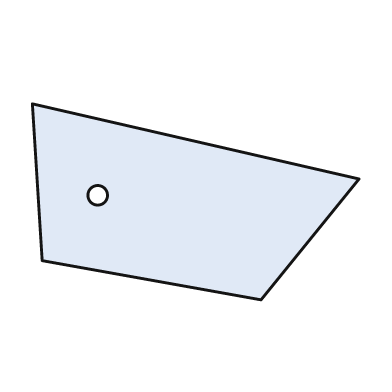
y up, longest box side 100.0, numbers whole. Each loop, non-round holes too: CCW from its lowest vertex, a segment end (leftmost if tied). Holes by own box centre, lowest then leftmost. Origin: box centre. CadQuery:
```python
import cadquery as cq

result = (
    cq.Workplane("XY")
    .moveTo(20.0, -30.0)
    .lineTo(50.0, 7.0)
    .lineTo(-50.0, 30.0)
    .lineTo(-47.0, -18.0)
    .close()
    .moveTo(-30.0, 2.0)
    .circle(3.0)
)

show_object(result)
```